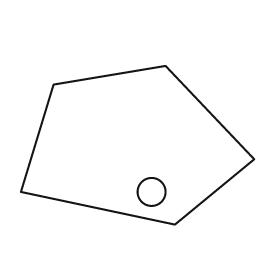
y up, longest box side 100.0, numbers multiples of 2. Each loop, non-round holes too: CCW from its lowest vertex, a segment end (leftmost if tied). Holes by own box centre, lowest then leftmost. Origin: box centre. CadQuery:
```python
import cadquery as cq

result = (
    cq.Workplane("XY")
    .moveTo(16.0, -34.0)
    .lineTo(50.0, -6.0)
    .lineTo(12.0, 34.0)
    .lineTo(-36.0, 26.0)
    .lineTo(-50.0, -20.0)
    .close()
    .moveTo(6.0, -20.0)
    .circle(6.0)
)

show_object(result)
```